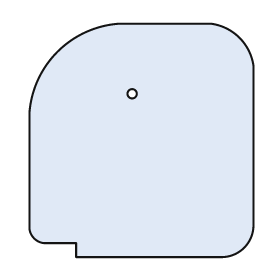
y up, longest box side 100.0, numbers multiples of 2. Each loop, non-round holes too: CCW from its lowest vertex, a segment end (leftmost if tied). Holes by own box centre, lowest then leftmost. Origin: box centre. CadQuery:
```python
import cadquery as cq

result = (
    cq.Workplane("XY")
    .moveTo(-28.0, -50.0)
    .lineTo(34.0, -50.0)
    .threePointArc((44.0, -46.0), (48.0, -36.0))
    .lineTo(48.0, 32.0)
    .threePointArc((42.0, 44.0), (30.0, 50.0))
    .lineTo(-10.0, 50.0)
    .threePointArc((-36.0, 38.0), (-48.0, 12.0))
    .lineTo(-48.0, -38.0)
    .threePointArc((-46.0, -42.0), (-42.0, -44.0))
    .lineTo(-28.0, -44.0)
    .close()
    .moveTo(-4.0, 20.0)
    .circle(2.0)
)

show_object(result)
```